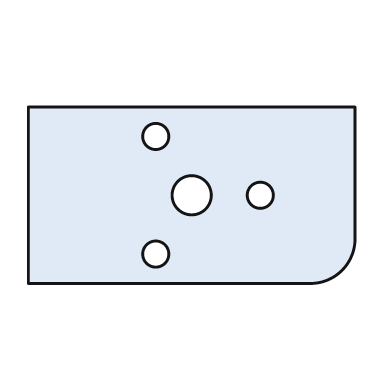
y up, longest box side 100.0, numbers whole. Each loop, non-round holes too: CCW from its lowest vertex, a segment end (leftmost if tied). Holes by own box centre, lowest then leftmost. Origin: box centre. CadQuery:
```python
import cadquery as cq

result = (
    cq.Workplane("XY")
    .moveTo(-50.0, -27.0)
    .lineTo(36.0, -27.0)
    .threePointArc((46.0, -23.0), (50.0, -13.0))
    .lineTo(50.0, 27.0)
    .lineTo(-50.0, 27.0)
    .close()
    .moveTo(-11.0, -18.0)
    .circle(4.0)
    .moveTo(0.0, 0.0)
    .circle(6.0)
    .moveTo(21.0, 0.0)
    .circle(4.0)
    .moveTo(-11.0, 18.0)
    .circle(4.0)
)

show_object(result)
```